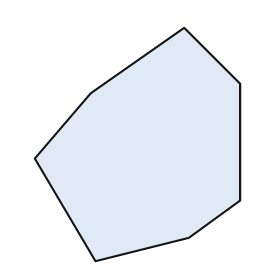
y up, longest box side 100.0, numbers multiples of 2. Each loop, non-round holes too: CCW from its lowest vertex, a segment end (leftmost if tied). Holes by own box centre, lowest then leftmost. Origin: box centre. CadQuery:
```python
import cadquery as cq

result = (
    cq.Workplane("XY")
    .moveTo(-18.0, -50.0)
    .lineTo(22.0, -40.0)
    .lineTo(44.0, -24.0)
    .lineTo(44.0, 26.0)
    .lineTo(20.0, 50.0)
    .lineTo(-20.0, 22.0)
    .lineTo(-44.0, -6.0)
    .close()
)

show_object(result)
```